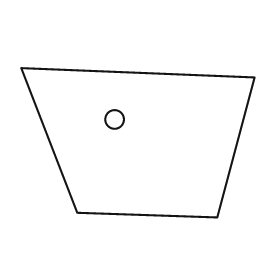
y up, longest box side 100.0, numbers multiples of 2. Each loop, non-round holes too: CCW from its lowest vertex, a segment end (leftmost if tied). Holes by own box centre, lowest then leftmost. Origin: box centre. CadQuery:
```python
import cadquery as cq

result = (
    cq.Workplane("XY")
    .moveTo(34.0, -32.0)
    .lineTo(50.0, 28.0)
    .lineTo(-50.0, 32.0)
    .lineTo(-26.0, -30.0)
    .close()
    .moveTo(-10.0, 10.0)
    .circle(4.0)
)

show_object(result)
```